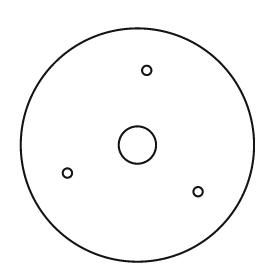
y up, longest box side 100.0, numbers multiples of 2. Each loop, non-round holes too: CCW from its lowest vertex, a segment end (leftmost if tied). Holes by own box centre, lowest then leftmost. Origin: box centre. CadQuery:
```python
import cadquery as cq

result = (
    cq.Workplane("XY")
    .moveTo(0.0, 0.0)
    .circle(50.0)
    .moveTo(26.0, -20.0)
    .circle(2.0)
    .moveTo(-30.0, -12.0)
    .circle(2.0)
    .moveTo(0.0, 0.0)
    .circle(8.0)
    .moveTo(4.0, 32.0)
    .circle(2.0)
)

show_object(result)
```